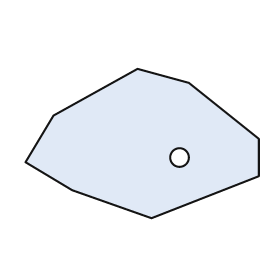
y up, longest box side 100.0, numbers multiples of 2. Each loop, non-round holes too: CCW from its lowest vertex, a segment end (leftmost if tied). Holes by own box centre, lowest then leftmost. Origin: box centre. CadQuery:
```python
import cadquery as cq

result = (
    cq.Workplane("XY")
    .moveTo(4.0, -32.0)
    .lineTo(50.0, -14.0)
    .lineTo(50.0, 2.0)
    .lineTo(20.0, 26.0)
    .lineTo(-2.0, 32.0)
    .lineTo(-38.0, 12.0)
    .lineTo(-50.0, -8.0)
    .lineTo(-30.0, -20.0)
    .close()
    .moveTo(16.0, -6.0)
    .circle(4.0)
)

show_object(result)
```